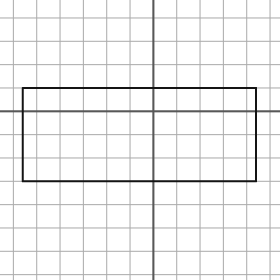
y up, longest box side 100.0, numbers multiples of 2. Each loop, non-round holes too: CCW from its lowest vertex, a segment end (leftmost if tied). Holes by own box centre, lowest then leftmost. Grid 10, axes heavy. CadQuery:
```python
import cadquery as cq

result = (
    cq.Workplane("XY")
    .moveTo(-56.0, -30.0)
    .lineTo(44.0, -30.0)
    .lineTo(44.0, 10.0)
    .lineTo(-56.0, 10.0)
    .close()
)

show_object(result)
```